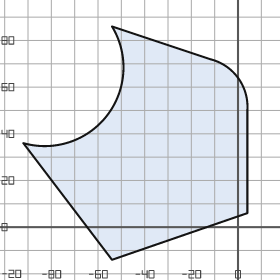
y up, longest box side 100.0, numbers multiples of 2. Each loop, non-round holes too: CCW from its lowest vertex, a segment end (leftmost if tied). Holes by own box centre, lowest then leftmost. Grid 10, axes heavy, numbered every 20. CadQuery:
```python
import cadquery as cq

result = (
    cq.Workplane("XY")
    .moveTo(-54.0, -14.0)
    .lineTo(4.0, 6.0)
    .lineTo(4.0, 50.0)
    .threePointArc((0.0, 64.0), (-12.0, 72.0))
    .lineTo(-54.0, 86.0)
    .threePointArc((-56.0, 48.0), (-92.0, 36.0))
    .close()
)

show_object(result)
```